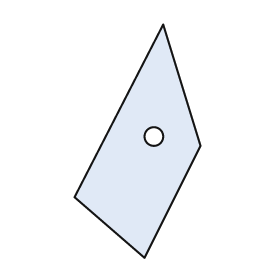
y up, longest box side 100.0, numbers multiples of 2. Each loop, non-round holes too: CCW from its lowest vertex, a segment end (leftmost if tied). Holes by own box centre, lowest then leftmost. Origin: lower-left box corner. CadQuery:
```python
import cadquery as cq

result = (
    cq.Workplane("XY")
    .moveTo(30.0, 0.0)
    .lineTo(54.0, 48.0)
    .lineTo(38.0, 100.0)
    .lineTo(0.0, 26.0)
    .close()
    .moveTo(34.0, 52.0)
    .circle(4.0)
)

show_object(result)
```